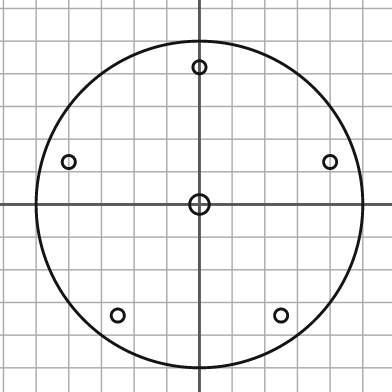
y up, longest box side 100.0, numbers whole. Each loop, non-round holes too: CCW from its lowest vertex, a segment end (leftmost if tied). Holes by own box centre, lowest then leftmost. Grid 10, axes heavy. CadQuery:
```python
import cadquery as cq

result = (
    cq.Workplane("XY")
    .moveTo(0.0, 0.0)
    .circle(50.0)
    .moveTo(-25.0, -34.0)
    .circle(2.0)
    .moveTo(25.0, -34.0)
    .circle(2.0)
    .moveTo(0.0, 0.0)
    .circle(3.0)
    .moveTo(-40.0, 13.0)
    .circle(2.0)
    .moveTo(40.0, 13.0)
    .circle(2.0)
    .moveTo(0.0, 42.0)
    .circle(2.0)
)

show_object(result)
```